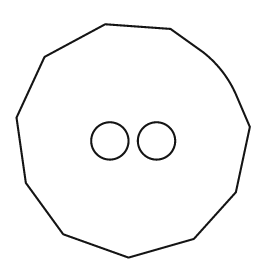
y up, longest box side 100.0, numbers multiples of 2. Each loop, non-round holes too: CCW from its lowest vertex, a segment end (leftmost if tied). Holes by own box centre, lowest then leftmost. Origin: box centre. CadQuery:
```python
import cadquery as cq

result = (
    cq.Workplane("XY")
    .moveTo(-2.0, -50.0)
    .lineTo(26.0, -42.0)
    .lineTo(44.0, -22.0)
    .lineTo(50.0, 6.0)
    .lineTo(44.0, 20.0)
    .threePointArc((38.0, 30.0), (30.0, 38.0))
    .lineTo(16.0, 48.0)
    .lineTo(-12.0, 50.0)
    .lineTo(-38.0, 36.0)
    .lineTo(-50.0, 10.0)
    .lineTo(-46.0, -18.0)
    .lineTo(-30.0, -40.0)
    .close()
    .moveTo(-10.0, 0.0)
    .circle(8.0)
    .moveTo(10.0, 0.0)
    .circle(8.0)
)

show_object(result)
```